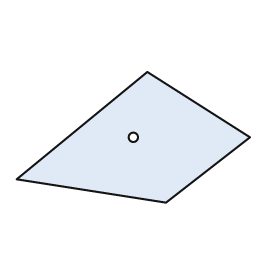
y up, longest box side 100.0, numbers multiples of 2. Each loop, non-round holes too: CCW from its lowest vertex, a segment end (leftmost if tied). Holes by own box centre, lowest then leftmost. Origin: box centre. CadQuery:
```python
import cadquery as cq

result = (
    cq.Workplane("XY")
    .moveTo(14.0, -28.0)
    .lineTo(50.0, 0.0)
    .lineTo(6.0, 28.0)
    .lineTo(-50.0, -18.0)
    .close()
    .moveTo(0.0, 0.0)
    .circle(2.0)
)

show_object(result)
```